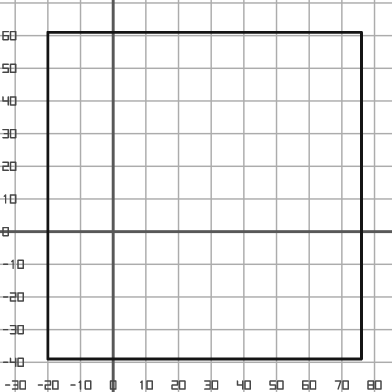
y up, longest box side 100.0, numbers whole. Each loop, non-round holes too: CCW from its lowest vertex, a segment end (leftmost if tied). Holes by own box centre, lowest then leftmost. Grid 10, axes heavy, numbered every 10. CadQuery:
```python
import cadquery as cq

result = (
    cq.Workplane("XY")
    .moveTo(-20.0, -39.0)
    .lineTo(76.0, -39.0)
    .lineTo(76.0, 61.0)
    .lineTo(-20.0, 61.0)
    .close()
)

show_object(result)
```